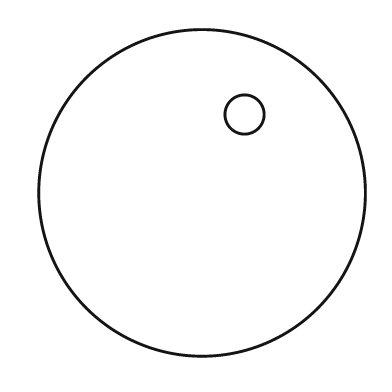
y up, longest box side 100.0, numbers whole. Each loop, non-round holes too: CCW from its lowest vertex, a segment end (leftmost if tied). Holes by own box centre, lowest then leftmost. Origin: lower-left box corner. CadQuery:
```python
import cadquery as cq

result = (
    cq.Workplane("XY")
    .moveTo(50.0, 50.0)
    .circle(50.0)
    .moveTo(63.0, 74.0)
    .circle(6.0)
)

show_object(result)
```